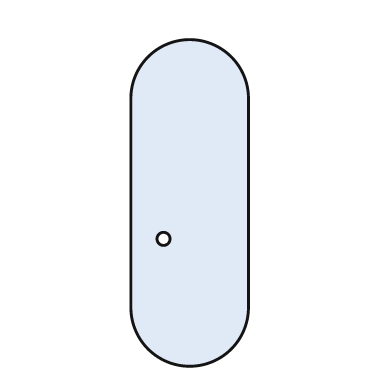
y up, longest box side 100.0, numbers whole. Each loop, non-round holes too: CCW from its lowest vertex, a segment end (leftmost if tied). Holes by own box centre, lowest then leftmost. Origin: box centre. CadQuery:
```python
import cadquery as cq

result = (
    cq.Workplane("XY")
    .moveTo(-18.0, -32.0)
    .threePointArc((0.0, -50.0), (18.0, -32.0))
    .lineTo(18.0, 32.0)
    .threePointArc((0.0, 50.0), (-18.0, 32.0))
    .close()
    .moveTo(-8.0, -11.0)
    .circle(2.0)
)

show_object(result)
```